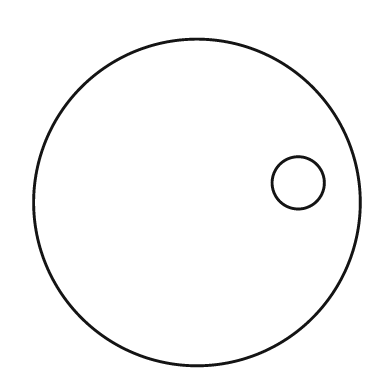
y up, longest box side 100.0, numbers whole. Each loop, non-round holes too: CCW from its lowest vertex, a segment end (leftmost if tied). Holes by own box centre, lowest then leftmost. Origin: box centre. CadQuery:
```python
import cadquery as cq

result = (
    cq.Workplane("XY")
    .moveTo(0.0, 0.0)
    .circle(50.0)
    .moveTo(31.0, 6.0)
    .circle(8.0)
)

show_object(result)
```